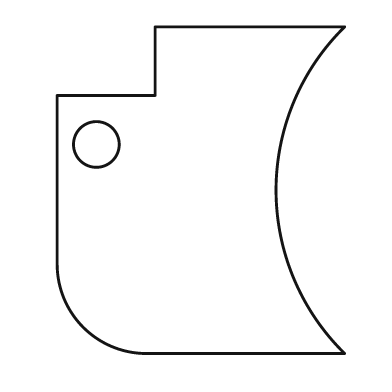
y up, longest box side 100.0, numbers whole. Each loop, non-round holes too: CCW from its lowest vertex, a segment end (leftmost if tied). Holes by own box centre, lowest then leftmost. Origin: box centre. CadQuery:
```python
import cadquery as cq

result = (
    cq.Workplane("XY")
    .moveTo(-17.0, -50.0)
    .lineTo(44.0, -50.0)
    .threePointArc((23.0, 0.0), (44.0, 50.0))
    .lineTo(-14.0, 50.0)
    .lineTo(-14.0, 29.0)
    .lineTo(-44.0, 29.0)
    .lineTo(-44.0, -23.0)
    .threePointArc((-36.0, -42.0), (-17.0, -50.0))
    .close()
    .moveTo(-32.0, 14.0)
    .circle(7.0)
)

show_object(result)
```